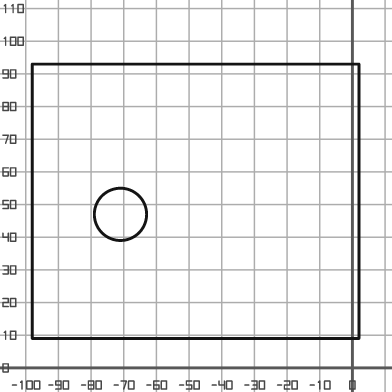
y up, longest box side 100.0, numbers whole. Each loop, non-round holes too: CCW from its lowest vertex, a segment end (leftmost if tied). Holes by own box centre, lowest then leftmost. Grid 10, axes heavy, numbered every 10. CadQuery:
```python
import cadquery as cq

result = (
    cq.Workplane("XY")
    .moveTo(-98.0, 9.0)
    .lineTo(2.0, 9.0)
    .lineTo(2.0, 93.0)
    .lineTo(-98.0, 93.0)
    .close()
    .moveTo(-71.0, 47.0)
    .circle(8.0)
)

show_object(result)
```